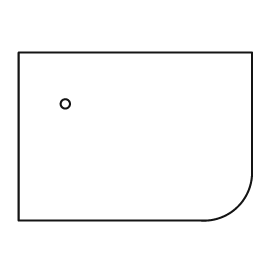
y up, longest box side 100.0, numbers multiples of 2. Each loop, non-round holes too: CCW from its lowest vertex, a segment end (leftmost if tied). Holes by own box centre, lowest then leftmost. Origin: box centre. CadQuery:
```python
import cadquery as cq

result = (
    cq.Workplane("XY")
    .moveTo(-50.0, -36.0)
    .lineTo(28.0, -36.0)
    .threePointArc((44.0, -30.0), (50.0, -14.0))
    .lineTo(50.0, 36.0)
    .lineTo(-50.0, 36.0)
    .close()
    .moveTo(-30.0, 14.0)
    .circle(2.0)
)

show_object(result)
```